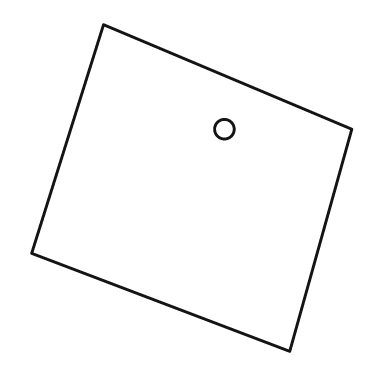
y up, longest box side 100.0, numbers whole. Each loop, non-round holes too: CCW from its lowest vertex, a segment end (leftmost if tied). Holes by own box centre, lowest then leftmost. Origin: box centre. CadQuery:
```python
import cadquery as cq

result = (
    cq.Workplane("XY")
    .moveTo(30.0, -50.0)
    .lineTo(49.0, 18.0)
    .lineTo(-27.0, 50.0)
    .lineTo(-49.0, -20.0)
    .close()
    .moveTo(10.0, 18.0)
    .circle(3.0)
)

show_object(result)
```